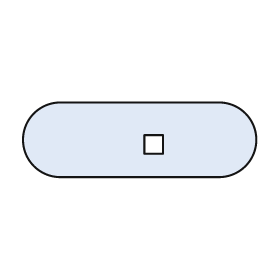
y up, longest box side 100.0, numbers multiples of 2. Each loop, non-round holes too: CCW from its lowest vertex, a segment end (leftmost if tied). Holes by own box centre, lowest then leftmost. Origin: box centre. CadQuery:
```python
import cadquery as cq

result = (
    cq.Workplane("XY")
    .moveTo(-34.0, -16.0)
    .lineTo(34.0, -16.0)
    .threePointArc((50.0, 0.0), (34.0, 16.0))
    .lineTo(-34.0, 16.0)
    .threePointArc((-50.0, 0.0), (-34.0, -16.0))
    .close()
    .moveTo(2.0, -6.0)
    .lineTo(10.0, -6.0)
    .lineTo(10.0, 2.0)
    .lineTo(2.0, 2.0)
    .close()
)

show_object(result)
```